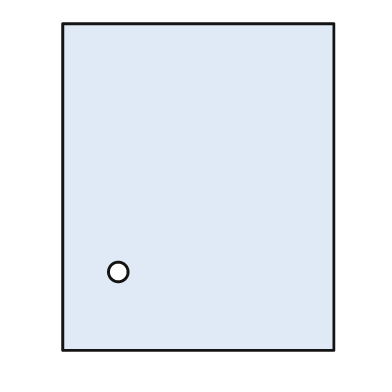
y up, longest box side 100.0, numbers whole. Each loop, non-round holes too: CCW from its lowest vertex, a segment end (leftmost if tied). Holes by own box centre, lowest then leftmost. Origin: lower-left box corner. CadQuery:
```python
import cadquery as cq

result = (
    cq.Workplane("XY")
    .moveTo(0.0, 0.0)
    .lineTo(83.0, 0.0)
    .lineTo(83.0, 100.0)
    .lineTo(0.0, 100.0)
    .close()
    .moveTo(17.0, 24.0)
    .circle(3.0)
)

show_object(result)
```